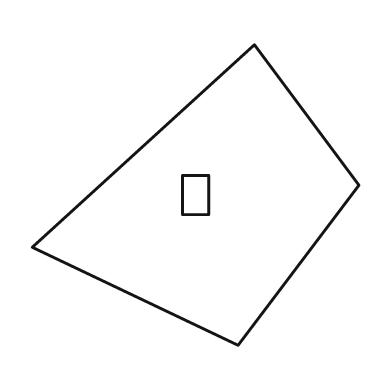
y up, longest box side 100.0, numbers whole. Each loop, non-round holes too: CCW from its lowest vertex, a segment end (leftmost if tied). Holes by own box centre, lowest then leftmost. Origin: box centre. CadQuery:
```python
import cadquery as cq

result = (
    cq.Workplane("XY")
    .moveTo(13.0, -46.0)
    .lineTo(50.0, 3.0)
    .lineTo(18.0, 46.0)
    .lineTo(-50.0, -16.0)
    .close()
    .moveTo(-4.0, -6.0)
    .lineTo(4.0, -6.0)
    .lineTo(4.0, 6.0)
    .lineTo(-4.0, 6.0)
    .close()
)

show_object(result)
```